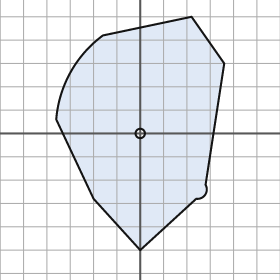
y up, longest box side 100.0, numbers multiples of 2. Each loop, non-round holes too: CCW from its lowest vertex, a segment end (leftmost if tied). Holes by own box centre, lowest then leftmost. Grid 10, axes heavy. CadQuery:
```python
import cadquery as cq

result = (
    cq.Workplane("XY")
    .moveTo(0.0, -50.0)
    .lineTo(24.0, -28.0)
    .threePointArc((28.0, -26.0), (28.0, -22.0))
    .lineTo(36.0, 30.0)
    .lineTo(22.0, 50.0)
    .lineTo(-16.0, 42.0)
    .threePointArc((-30.0, 26.0), (-36.0, 6.0))
    .lineTo(-20.0, -28.0)
    .close()
    .moveTo(0.0, 0.0)
    .circle(2.0)
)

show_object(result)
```